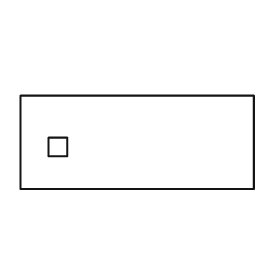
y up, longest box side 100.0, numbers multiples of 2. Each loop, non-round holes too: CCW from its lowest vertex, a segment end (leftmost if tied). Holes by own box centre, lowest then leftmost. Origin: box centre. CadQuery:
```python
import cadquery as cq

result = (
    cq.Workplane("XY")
    .moveTo(-50.0, -20.0)
    .lineTo(50.0, -20.0)
    .lineTo(50.0, 20.0)
    .lineTo(-50.0, 20.0)
    .close()
    .moveTo(-38.0, -6.0)
    .lineTo(-30.0, -6.0)
    .lineTo(-30.0, 2.0)
    .lineTo(-38.0, 2.0)
    .close()
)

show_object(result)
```